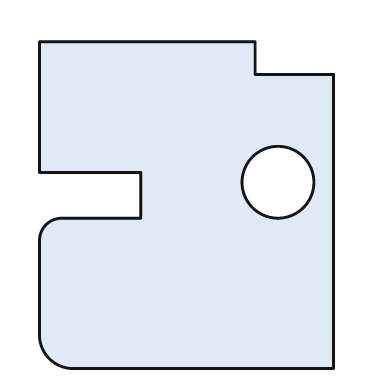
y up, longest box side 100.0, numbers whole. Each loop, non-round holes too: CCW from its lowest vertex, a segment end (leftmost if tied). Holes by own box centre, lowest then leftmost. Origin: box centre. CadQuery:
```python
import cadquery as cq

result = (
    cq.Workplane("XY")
    .moveTo(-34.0, -50.0)
    .lineTo(45.0, -50.0)
    .lineTo(45.0, 40.0)
    .lineTo(21.0, 40.0)
    .lineTo(21.0, 50.0)
    .lineTo(-45.0, 50.0)
    .lineTo(-45.0, 10.0)
    .lineTo(-14.0, 10.0)
    .lineTo(-14.0, -4.0)
    .lineTo(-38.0, -4.0)
    .threePointArc((-43.0, -6.0), (-45.0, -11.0))
    .lineTo(-45.0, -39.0)
    .threePointArc((-42.0, -47.0), (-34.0, -50.0))
    .close()
    .moveTo(28.0, 7.0)
    .circle(11.0)
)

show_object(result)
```